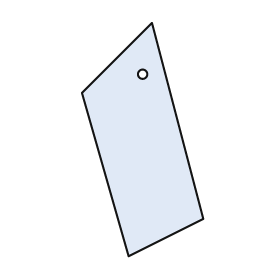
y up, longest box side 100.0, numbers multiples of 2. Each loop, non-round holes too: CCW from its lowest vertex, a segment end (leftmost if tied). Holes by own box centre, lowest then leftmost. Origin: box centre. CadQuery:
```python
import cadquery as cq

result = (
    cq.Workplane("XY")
    .moveTo(-6.0, -50.0)
    .lineTo(26.0, -34.0)
    .lineTo(4.0, 50.0)
    .lineTo(-26.0, 20.0)
    .close()
    .moveTo(0.0, 28.0)
    .circle(2.0)
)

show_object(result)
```